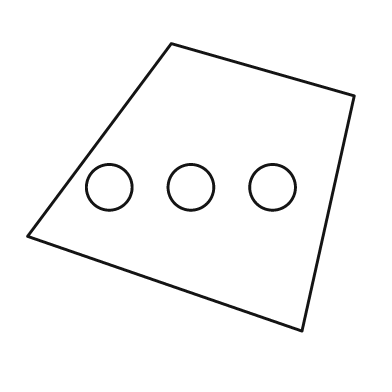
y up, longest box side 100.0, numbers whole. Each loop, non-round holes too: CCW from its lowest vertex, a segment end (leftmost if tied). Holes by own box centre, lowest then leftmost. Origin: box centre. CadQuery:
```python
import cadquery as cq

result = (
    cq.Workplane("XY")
    .moveTo(34.0, -44.0)
    .lineTo(50.0, 28.0)
    .lineTo(-6.0, 44.0)
    .lineTo(-50.0, -15.0)
    .close()
    .moveTo(-25.0, 0.0)
    .circle(7.0)
    .moveTo(0.0, 0.0)
    .circle(7.0)
    .moveTo(25.0, 0.0)
    .circle(7.0)
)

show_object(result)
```